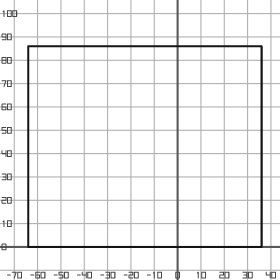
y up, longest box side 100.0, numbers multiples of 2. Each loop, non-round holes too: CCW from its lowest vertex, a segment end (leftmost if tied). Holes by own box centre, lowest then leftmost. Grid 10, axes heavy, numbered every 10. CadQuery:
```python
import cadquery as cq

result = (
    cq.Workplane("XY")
    .moveTo(-64.0, 0.0)
    .lineTo(36.0, 0.0)
    .lineTo(36.0, 86.0)
    .lineTo(-64.0, 86.0)
    .close()
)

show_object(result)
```